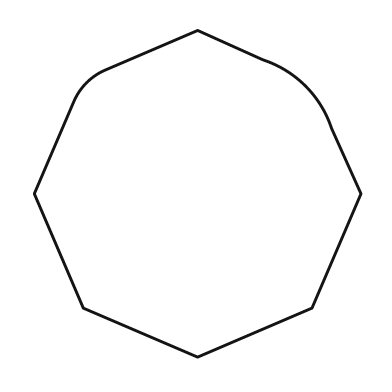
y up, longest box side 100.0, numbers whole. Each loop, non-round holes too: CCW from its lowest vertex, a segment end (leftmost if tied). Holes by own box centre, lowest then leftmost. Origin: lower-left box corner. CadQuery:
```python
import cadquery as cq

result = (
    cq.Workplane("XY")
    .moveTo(50.0, 0.0)
    .lineTo(85.0, 15.0)
    .lineTo(100.0, 50.0)
    .lineTo(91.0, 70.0)
    .threePointArc((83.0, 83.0), (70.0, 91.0))
    .lineTo(50.0, 100.0)
    .lineTo(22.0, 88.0)
    .threePointArc((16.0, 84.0), (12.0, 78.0))
    .lineTo(0.0, 50.0)
    .lineTo(15.0, 15.0)
    .close()
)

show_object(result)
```